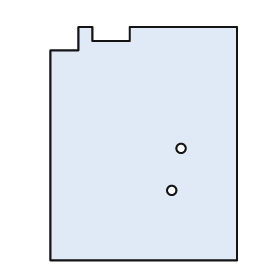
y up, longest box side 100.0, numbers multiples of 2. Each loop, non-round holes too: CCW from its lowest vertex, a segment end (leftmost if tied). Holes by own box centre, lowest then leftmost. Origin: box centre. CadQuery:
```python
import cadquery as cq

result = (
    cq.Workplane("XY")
    .moveTo(-40.0, -50.0)
    .lineTo(40.0, -50.0)
    .lineTo(40.0, 50.0)
    .lineTo(-6.0, 50.0)
    .lineTo(-6.0, 44.0)
    .lineTo(-22.0, 44.0)
    .lineTo(-22.0, 50.0)
    .lineTo(-28.0, 50.0)
    .lineTo(-28.0, 40.0)
    .lineTo(-40.0, 40.0)
    .close()
    .moveTo(12.0, -20.0)
    .circle(2.0)
    .moveTo(16.0, -2.0)
    .circle(2.0)
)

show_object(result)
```